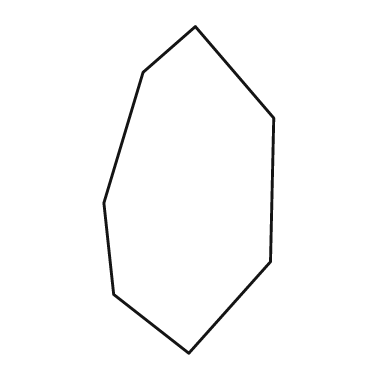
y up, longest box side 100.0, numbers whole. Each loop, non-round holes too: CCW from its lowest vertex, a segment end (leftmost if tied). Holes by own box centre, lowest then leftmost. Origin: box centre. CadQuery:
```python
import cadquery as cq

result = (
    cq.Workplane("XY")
    .moveTo(0.0, -50.0)
    .lineTo(25.0, -22.0)
    .lineTo(26.0, 22.0)
    .lineTo(2.0, 50.0)
    .lineTo(-14.0, 36.0)
    .lineTo(-26.0, -4.0)
    .lineTo(-23.0, -32.0)
    .close()
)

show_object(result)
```